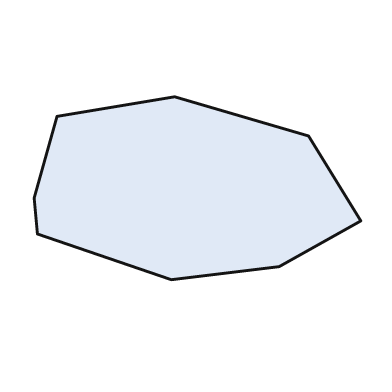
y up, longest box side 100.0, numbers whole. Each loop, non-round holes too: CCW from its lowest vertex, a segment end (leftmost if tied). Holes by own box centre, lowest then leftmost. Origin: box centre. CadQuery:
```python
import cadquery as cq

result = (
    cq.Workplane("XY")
    .moveTo(-8.0, -28.0)
    .lineTo(25.0, -24.0)
    .lineTo(50.0, -10.0)
    .lineTo(34.0, 16.0)
    .lineTo(-7.0, 28.0)
    .lineTo(-43.0, 22.0)
    .lineTo(-50.0, -3.0)
    .lineTo(-49.0, -14.0)
    .close()
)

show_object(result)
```